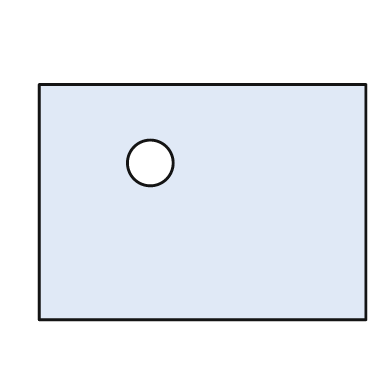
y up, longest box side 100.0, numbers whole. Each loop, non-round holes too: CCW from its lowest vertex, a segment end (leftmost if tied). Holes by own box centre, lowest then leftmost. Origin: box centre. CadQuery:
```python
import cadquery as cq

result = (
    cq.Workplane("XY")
    .moveTo(-50.0, -36.0)
    .lineTo(50.0, -36.0)
    .lineTo(50.0, 36.0)
    .lineTo(-50.0, 36.0)
    .close()
    .moveTo(-16.0, 12.0)
    .circle(7.0)
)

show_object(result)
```